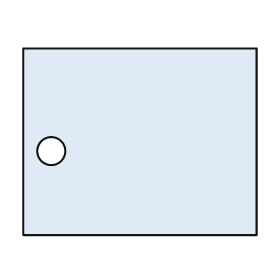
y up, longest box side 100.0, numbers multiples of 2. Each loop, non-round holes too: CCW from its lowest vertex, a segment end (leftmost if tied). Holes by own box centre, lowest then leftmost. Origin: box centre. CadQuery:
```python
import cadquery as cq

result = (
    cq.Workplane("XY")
    .moveTo(-50.0, -40.0)
    .lineTo(50.0, -40.0)
    .lineTo(50.0, 40.0)
    .lineTo(-50.0, 40.0)
    .close()
    .moveTo(-38.0, -4.0)
    .circle(6.0)
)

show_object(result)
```